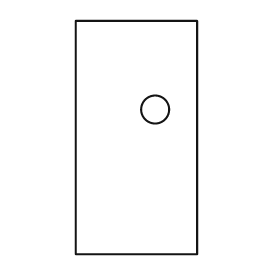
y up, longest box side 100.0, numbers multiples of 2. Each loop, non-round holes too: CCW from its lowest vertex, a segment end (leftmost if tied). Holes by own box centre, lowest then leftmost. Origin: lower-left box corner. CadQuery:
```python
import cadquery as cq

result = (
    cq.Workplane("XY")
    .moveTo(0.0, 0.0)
    .lineTo(52.0, 0.0)
    .lineTo(52.0, 100.0)
    .lineTo(0.0, 100.0)
    .close()
    .moveTo(34.0, 62.0)
    .circle(6.0)
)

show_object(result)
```